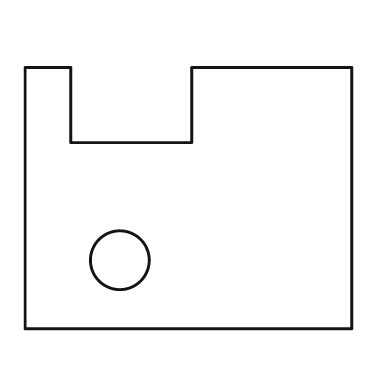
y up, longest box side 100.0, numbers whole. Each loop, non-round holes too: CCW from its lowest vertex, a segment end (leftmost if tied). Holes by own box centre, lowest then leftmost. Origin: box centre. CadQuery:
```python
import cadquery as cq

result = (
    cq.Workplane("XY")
    .moveTo(-50.0, -40.0)
    .lineTo(50.0, -40.0)
    .lineTo(50.0, 40.0)
    .lineTo(1.0, 40.0)
    .lineTo(1.0, 17.0)
    .lineTo(-36.0, 17.0)
    .lineTo(-36.0, 40.0)
    .lineTo(-50.0, 40.0)
    .close()
    .moveTo(-21.0, -19.0)
    .circle(9.0)
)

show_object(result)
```